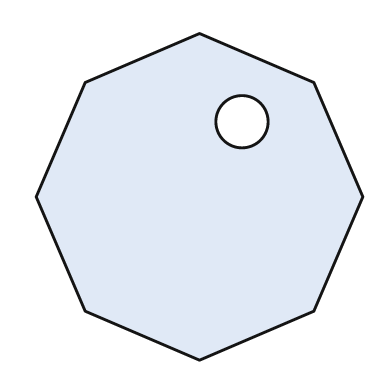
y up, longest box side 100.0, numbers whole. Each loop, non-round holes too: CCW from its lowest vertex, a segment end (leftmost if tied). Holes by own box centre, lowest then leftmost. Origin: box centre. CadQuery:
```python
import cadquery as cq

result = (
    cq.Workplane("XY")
    .moveTo(0.0, -50.0)
    .lineTo(35.0, -35.0)
    .lineTo(50.0, 0.0)
    .lineTo(35.0, 35.0)
    .lineTo(0.0, 50.0)
    .lineTo(-35.0, 35.0)
    .lineTo(-50.0, 0.0)
    .lineTo(-35.0, -35.0)
    .close()
    .moveTo(13.0, 23.0)
    .circle(8.0)
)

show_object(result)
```